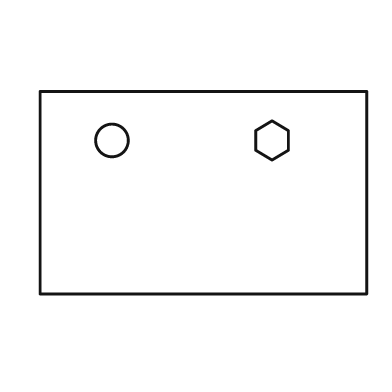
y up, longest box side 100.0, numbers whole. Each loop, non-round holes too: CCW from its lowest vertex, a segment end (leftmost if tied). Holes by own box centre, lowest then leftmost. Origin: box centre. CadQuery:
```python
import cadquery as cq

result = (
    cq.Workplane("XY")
    .moveTo(-50.0, -31.0)
    .lineTo(50.0, -31.0)
    .lineTo(50.0, 31.0)
    .lineTo(-50.0, 31.0)
    .close()
    .moveTo(-28.0, 16.0)
    .circle(5.0)
    .moveTo(21.0, 10.0)
    .lineTo(26.0, 13.0)
    .lineTo(26.0, 19.0)
    .lineTo(21.0, 22.0)
    .lineTo(16.0, 19.0)
    .lineTo(16.0, 13.0)
    .close()
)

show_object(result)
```